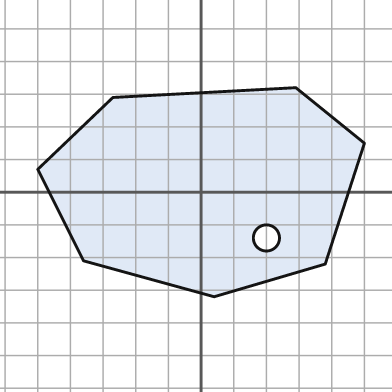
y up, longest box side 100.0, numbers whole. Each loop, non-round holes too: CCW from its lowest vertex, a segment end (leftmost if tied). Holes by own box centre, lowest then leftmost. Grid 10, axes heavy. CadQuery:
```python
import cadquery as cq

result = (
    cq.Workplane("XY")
    .moveTo(4.0, -32.0)
    .lineTo(38.0, -22.0)
    .lineTo(50.0, 15.0)
    .lineTo(29.0, 32.0)
    .lineTo(-27.0, 29.0)
    .lineTo(-50.0, 7.0)
    .lineTo(-36.0, -21.0)
    .close()
    .moveTo(20.0, -14.0)
    .circle(4.0)
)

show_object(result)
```